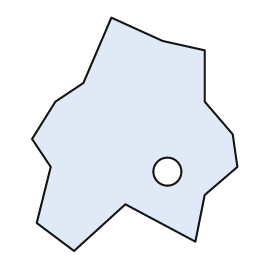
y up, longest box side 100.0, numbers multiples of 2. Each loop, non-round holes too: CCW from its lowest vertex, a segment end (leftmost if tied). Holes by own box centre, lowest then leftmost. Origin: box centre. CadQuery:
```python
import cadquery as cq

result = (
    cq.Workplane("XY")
    .moveTo(-26.0, -50.0)
    .lineTo(-4.0, -30.0)
    .lineTo(26.0, -46.0)
    .lineTo(30.0, -26.0)
    .lineTo(44.0, -14.0)
    .lineTo(42.0, 0.0)
    .lineTo(30.0, 14.0)
    .lineTo(30.0, 36.0)
    .lineTo(12.0, 40.0)
    .lineTo(-10.0, 50.0)
    .lineTo(-22.0, 22.0)
    .lineTo(-34.0, 14.0)
    .lineTo(-44.0, -2.0)
    .lineTo(-36.0, -14.0)
    .lineTo(-42.0, -38.0)
    .close()
    .moveTo(14.0, -16.0)
    .circle(6.0)
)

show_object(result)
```